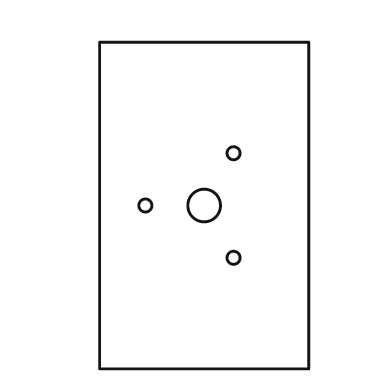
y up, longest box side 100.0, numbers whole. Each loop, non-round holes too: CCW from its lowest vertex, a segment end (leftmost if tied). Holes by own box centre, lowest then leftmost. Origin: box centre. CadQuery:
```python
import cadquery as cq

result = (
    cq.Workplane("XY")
    .moveTo(-32.0, -50.0)
    .lineTo(32.0, -50.0)
    .lineTo(32.0, 50.0)
    .lineTo(-32.0, 50.0)
    .close()
    .moveTo(9.0, -16.0)
    .circle(2.0)
    .moveTo(-18.0, 0.0)
    .circle(2.0)
    .moveTo(0.0, 0.0)
    .circle(5.0)
    .moveTo(9.0, 16.0)
    .circle(2.0)
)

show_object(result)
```